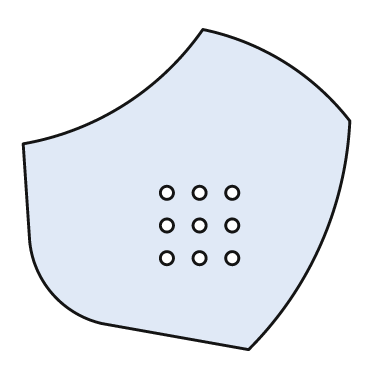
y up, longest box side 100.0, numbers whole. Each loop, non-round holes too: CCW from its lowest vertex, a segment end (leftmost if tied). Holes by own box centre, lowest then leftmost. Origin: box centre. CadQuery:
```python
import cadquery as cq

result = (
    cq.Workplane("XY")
    .moveTo(19.0, -49.0)
    .threePointArc((41.0, -17.0), (50.0, 21.0))
    .threePointArc((30.0, 39.0), (5.0, 49.0))
    .threePointArc((-19.0, 26.0), (-50.0, 14.0))
    .lineTo(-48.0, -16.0)
    .threePointArc((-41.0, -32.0), (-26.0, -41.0))
    .close()
    .moveTo(-6.0, -21.0)
    .circle(2.0)
    .moveTo(4.0, -21.0)
    .circle(2.0)
    .moveTo(14.0, -21.0)
    .circle(2.0)
    .moveTo(-6.0, -11.0)
    .circle(2.0)
    .moveTo(4.0, -11.0)
    .circle(2.0)
    .moveTo(14.0, -11.0)
    .circle(2.0)
    .moveTo(-6.0, -1.0)
    .circle(2.0)
    .moveTo(4.0, -1.0)
    .circle(2.0)
    .moveTo(14.0, -1.0)
    .circle(2.0)
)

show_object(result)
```